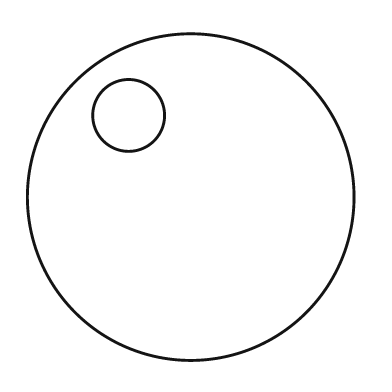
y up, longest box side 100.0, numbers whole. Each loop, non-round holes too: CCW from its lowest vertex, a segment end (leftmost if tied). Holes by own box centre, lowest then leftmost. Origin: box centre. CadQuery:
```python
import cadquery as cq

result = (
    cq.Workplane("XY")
    .moveTo(0.0, 0.0)
    .circle(50.0)
    .moveTo(-19.0, 25.0)
    .circle(11.0)
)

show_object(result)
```